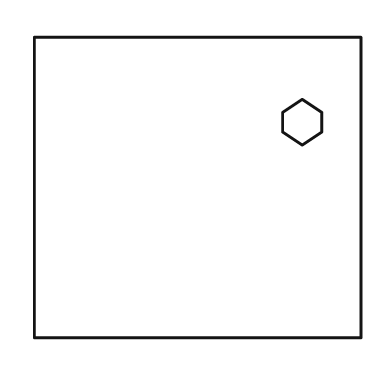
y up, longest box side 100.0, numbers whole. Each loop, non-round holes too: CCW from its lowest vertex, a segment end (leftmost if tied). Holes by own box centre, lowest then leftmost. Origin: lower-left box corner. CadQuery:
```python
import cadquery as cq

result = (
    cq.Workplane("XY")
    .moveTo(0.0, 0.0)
    .lineTo(100.0, 0.0)
    .lineTo(100.0, 92.0)
    .lineTo(0.0, 92.0)
    .close()
    .moveTo(82.0, 59.0)
    .lineTo(88.0, 63.0)
    .lineTo(88.0, 69.0)
    .lineTo(82.0, 73.0)
    .lineTo(76.0, 69.0)
    .lineTo(76.0, 63.0)
    .close()
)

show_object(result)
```